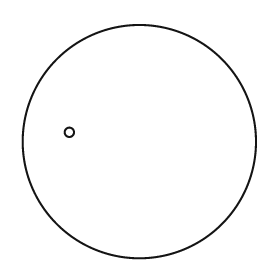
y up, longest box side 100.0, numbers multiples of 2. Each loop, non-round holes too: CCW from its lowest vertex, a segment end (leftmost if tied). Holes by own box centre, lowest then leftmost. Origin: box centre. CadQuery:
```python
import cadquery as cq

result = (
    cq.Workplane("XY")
    .moveTo(0.0, 0.0)
    .circle(50.0)
    .moveTo(-30.0, 4.0)
    .circle(2.0)
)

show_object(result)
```